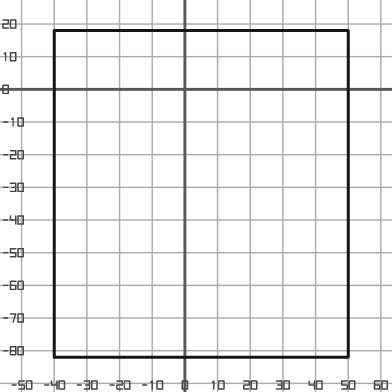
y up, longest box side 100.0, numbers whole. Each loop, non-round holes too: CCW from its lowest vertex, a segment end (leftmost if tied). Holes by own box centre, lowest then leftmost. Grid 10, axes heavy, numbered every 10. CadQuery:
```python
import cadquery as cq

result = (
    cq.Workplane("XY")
    .moveTo(-40.0, -82.0)
    .lineTo(50.0, -82.0)
    .lineTo(50.0, 18.0)
    .lineTo(-40.0, 18.0)
    .close()
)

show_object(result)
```